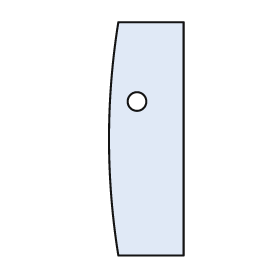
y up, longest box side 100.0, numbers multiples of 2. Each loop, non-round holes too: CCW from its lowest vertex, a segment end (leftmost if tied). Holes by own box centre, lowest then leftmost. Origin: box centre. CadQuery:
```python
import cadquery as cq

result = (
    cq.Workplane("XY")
    .moveTo(-12.0, -50.0)
    .lineTo(16.0, -50.0)
    .lineTo(16.0, 50.0)
    .lineTo(-12.0, 50.0)
    .threePointArc((-16.0, 0.0), (-12.0, -50.0))
    .close()
    .moveTo(-4.0, 16.0)
    .circle(4.0)
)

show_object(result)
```